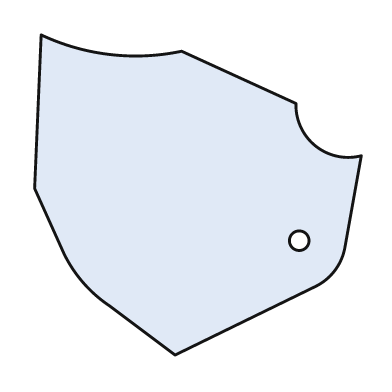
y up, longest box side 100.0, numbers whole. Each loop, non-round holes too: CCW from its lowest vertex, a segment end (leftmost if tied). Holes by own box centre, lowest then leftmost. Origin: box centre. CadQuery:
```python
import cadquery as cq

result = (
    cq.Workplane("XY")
    .moveTo(-7.0, -49.0)
    .lineTo(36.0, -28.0)
    .threePointArc((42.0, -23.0), (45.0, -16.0))
    .lineTo(50.0, 12.0)
    .threePointArc((36.0, 15.0), (30.0, 28.0))
    .lineTo(-5.0, 44.0)
    .threePointArc((-27.0, 43.0), (-48.0, 49.0))
    .lineTo(-50.0, 2.0)
    .lineTo(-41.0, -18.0)
    .threePointArc((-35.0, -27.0), (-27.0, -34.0))
    .close()
    .moveTo(31.0, -14.0)
    .circle(3.0)
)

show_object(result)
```